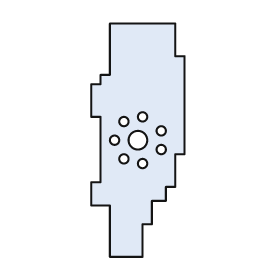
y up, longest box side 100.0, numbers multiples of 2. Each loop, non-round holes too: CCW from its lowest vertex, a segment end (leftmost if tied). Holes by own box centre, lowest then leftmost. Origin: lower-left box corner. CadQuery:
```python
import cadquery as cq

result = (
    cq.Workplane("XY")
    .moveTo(8.0, 0.0)
    .lineTo(22.0, 0.0)
    .lineTo(22.0, 14.0)
    .lineTo(26.0, 14.0)
    .lineTo(26.0, 24.0)
    .lineTo(32.0, 24.0)
    .lineTo(32.0, 30.0)
    .lineTo(36.0, 30.0)
    .lineTo(36.0, 44.0)
    .lineTo(40.0, 44.0)
    .lineTo(40.0, 86.0)
    .lineTo(36.0, 86.0)
    .lineTo(36.0, 100.0)
    .lineTo(8.0, 100.0)
    .lineTo(8.0, 78.0)
    .lineTo(4.0, 78.0)
    .lineTo(4.0, 74.0)
    .lineTo(0.0, 74.0)
    .lineTo(0.0, 60.0)
    .lineTo(4.0, 60.0)
    .lineTo(4.0, 32.0)
    .lineTo(0.0, 32.0)
    .lineTo(0.0, 22.0)
    .lineTo(8.0, 22.0)
    .close()
    .moveTo(22.0, 40.0)
    .circle(2.0)
    .moveTo(14.0, 42.0)
    .circle(2.0)
    .moveTo(30.0, 46.0)
    .circle(2.0)
    .moveTo(10.0, 50.0)
    .circle(2.0)
    .moveTo(20.0, 50.0)
    .circle(4.0)
    .moveTo(30.0, 54.0)
    .circle(2.0)
    .moveTo(14.0, 58.0)
    .circle(2.0)
    .moveTo(22.0, 60.0)
    .circle(2.0)
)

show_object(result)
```